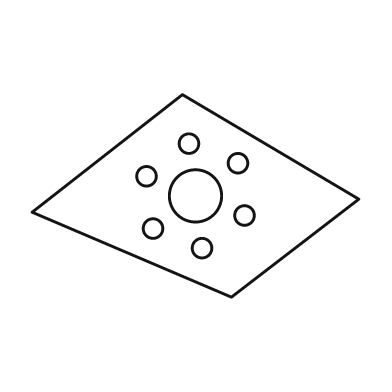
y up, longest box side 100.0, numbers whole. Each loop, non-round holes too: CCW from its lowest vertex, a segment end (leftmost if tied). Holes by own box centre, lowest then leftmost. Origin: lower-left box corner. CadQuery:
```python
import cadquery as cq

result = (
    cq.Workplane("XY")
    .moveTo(61.0, 0.0)
    .lineTo(100.0, 30.0)
    .lineTo(46.0, 62.0)
    .lineTo(0.0, 26.0)
    .close()
    .moveTo(52.0, 15.0)
    .circle(3.0)
    .moveTo(37.0, 21.0)
    .circle(3.0)
    .moveTo(65.0, 25.0)
    .circle(3.0)
    .moveTo(50.0, 31.0)
    .circle(8.0)
    .moveTo(35.0, 37.0)
    .circle(3.0)
    .moveTo(63.0, 41.0)
    .circle(3.0)
    .moveTo(48.0, 47.0)
    .circle(3.0)
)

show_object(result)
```